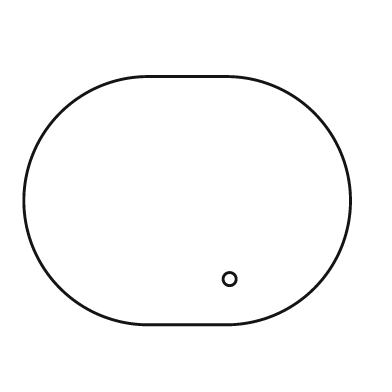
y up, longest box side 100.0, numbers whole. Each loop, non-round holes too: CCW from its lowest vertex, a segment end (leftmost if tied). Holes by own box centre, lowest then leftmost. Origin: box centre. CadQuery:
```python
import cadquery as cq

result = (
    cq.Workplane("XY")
    .moveTo(-12.0, -38.0)
    .lineTo(12.0, -38.0)
    .threePointArc((50.0, 0.0), (12.0, 38.0))
    .lineTo(-12.0, 38.0)
    .threePointArc((-50.0, 0.0), (-12.0, -38.0))
    .close()
    .moveTo(13.0, -24.0)
    .circle(2.0)
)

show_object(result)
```